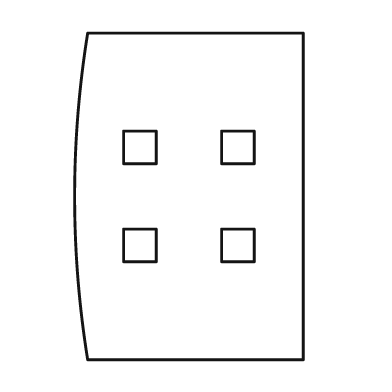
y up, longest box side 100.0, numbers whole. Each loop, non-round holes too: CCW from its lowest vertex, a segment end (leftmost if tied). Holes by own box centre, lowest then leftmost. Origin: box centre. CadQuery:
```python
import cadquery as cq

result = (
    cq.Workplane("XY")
    .moveTo(-31.0, -50.0)
    .lineTo(35.0, -50.0)
    .lineTo(35.0, 50.0)
    .lineTo(-31.0, 50.0)
    .threePointArc((-35.0, 0.0), (-31.0, -50.0))
    .close()
    .moveTo(-20.0, -20.0)
    .lineTo(-10.0, -20.0)
    .lineTo(-10.0, -10.0)
    .lineTo(-20.0, -10.0)
    .close()
    .moveTo(10.0, -20.0)
    .lineTo(20.0, -20.0)
    .lineTo(20.0, -10.0)
    .lineTo(10.0, -10.0)
    .close()
    .moveTo(-20.0, 10.0)
    .lineTo(-10.0, 10.0)
    .lineTo(-10.0, 20.0)
    .lineTo(-20.0, 20.0)
    .close()
    .moveTo(10.0, 10.0)
    .lineTo(20.0, 10.0)
    .lineTo(20.0, 20.0)
    .lineTo(10.0, 20.0)
    .close()
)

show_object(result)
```